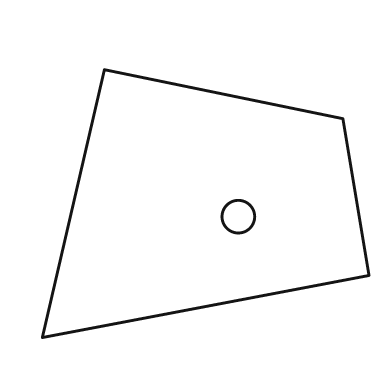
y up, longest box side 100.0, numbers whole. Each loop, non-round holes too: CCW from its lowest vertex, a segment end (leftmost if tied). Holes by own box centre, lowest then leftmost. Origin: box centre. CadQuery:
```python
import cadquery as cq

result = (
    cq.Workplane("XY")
    .moveTo(-50.0, -41.0)
    .lineTo(50.0, -22.0)
    .lineTo(42.0, 26.0)
    .lineTo(-31.0, 41.0)
    .close()
    .moveTo(10.0, -4.0)
    .circle(5.0)
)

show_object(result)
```